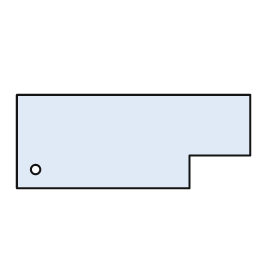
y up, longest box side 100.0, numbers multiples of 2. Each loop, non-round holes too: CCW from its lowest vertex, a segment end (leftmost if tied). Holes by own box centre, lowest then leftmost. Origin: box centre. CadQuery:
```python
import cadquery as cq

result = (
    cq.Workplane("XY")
    .moveTo(-50.0, -20.0)
    .lineTo(24.0, -20.0)
    .lineTo(24.0, -6.0)
    .lineTo(50.0, -6.0)
    .lineTo(50.0, 20.0)
    .lineTo(-50.0, 20.0)
    .close()
    .moveTo(-42.0, -12.0)
    .circle(2.0)
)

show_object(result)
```